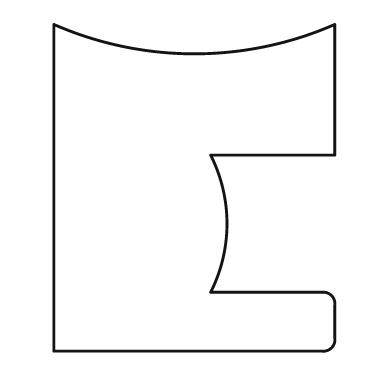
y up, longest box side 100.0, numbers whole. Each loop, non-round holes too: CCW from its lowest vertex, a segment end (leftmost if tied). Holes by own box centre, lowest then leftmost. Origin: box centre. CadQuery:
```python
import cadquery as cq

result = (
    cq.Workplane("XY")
    .moveTo(-43.0, -50.0)
    .lineTo(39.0, -50.0)
    .threePointArc((42.0, -49.0), (43.0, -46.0))
    .lineTo(43.0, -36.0)
    .threePointArc((42.0, -33.0), (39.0, -32.0))
    .lineTo(5.0, -32.0)
    .threePointArc((10.0, -11.0), (5.0, 10.0))
    .lineTo(43.0, 10.0)
    .lineTo(43.0, 50.0)
    .threePointArc((0.0, 41.0), (-43.0, 50.0))
    .close()
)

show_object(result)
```